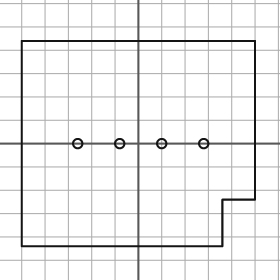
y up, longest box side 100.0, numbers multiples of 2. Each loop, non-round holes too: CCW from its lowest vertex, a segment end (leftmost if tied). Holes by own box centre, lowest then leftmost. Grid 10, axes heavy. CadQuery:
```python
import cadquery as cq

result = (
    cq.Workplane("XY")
    .moveTo(-50.0, -44.0)
    .lineTo(36.0, -44.0)
    .lineTo(36.0, -24.0)
    .lineTo(50.0, -24.0)
    .lineTo(50.0, 44.0)
    .lineTo(-50.0, 44.0)
    .close()
    .moveTo(-26.0, 0.0)
    .circle(2.0)
    .moveTo(-8.0, 0.0)
    .circle(2.0)
    .moveTo(10.0, 0.0)
    .circle(2.0)
    .moveTo(28.0, 0.0)
    .circle(2.0)
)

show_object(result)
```